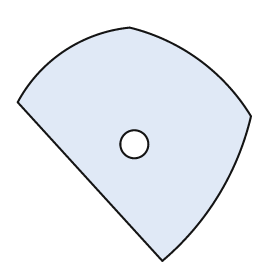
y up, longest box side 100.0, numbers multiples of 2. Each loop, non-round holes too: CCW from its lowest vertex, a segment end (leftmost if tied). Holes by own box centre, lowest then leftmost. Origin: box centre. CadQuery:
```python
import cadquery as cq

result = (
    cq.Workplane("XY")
    .moveTo(12.0, -50.0)
    .threePointArc((36.0, -22.0), (50.0, 12.0))
    .threePointArc((28.0, 36.0), (-2.0, 50.0))
    .threePointArc((-30.0, 40.0), (-50.0, 18.0))
    .close()
    .moveTo(0.0, 0.0)
    .circle(6.0)
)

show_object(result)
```